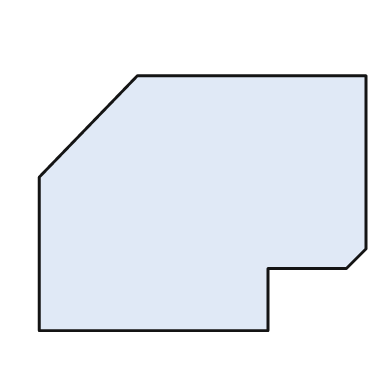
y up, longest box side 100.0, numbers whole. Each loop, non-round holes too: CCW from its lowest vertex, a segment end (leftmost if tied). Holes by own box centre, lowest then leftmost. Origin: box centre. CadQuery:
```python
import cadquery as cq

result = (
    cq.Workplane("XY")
    .moveTo(-50.0, -39.0)
    .lineTo(20.0, -39.0)
    .lineTo(20.0, -20.0)
    .lineTo(44.0, -20.0)
    .lineTo(50.0, -14.0)
    .lineTo(50.0, 39.0)
    .lineTo(-20.0, 39.0)
    .lineTo(-50.0, 8.0)
    .close()
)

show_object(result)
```